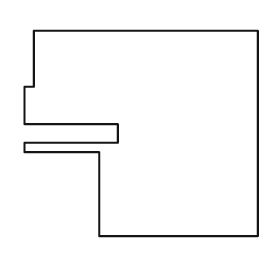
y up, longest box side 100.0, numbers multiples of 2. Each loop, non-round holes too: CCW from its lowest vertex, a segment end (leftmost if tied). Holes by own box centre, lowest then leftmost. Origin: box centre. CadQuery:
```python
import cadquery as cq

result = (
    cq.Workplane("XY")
    .moveTo(-18.0, -44.0)
    .lineTo(50.0, -44.0)
    .lineTo(50.0, 44.0)
    .lineTo(-46.0, 44.0)
    .lineTo(-46.0, 20.0)
    .lineTo(-50.0, 20.0)
    .lineTo(-50.0, 4.0)
    .lineTo(-10.0, 4.0)
    .lineTo(-10.0, -4.0)
    .lineTo(-50.0, -4.0)
    .lineTo(-50.0, -8.0)
    .lineTo(-18.0, -8.0)
    .close()
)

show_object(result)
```